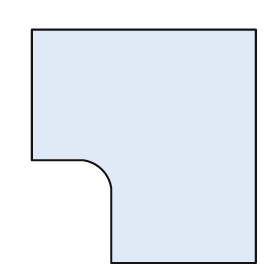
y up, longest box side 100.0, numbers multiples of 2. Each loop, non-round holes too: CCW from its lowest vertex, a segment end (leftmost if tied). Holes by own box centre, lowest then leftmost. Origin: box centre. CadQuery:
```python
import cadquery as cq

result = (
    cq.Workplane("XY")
    .moveTo(-14.0, -50.0)
    .lineTo(48.0, -50.0)
    .lineTo(48.0, 50.0)
    .lineTo(-48.0, 50.0)
    .lineTo(-48.0, -6.0)
    .lineTo(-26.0, -6.0)
    .threePointArc((-18.0, -10.0), (-14.0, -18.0))
    .close()
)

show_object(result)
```